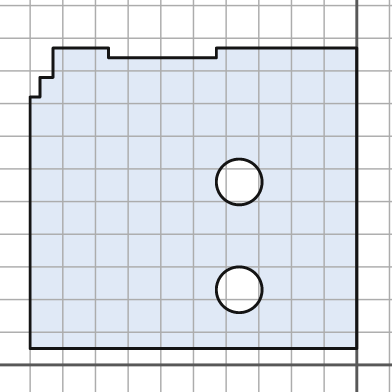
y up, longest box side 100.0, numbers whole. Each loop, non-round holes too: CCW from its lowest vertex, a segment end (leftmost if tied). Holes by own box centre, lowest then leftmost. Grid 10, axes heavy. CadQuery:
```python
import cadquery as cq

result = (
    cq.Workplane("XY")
    .moveTo(-100.0, 5.0)
    .lineTo(0.0, 5.0)
    .lineTo(0.0, 97.0)
    .lineTo(-43.0, 97.0)
    .lineTo(-43.0, 94.0)
    .lineTo(-76.0, 94.0)
    .lineTo(-76.0, 97.0)
    .lineTo(-93.0, 97.0)
    .lineTo(-93.0, 88.0)
    .lineTo(-97.0, 88.0)
    .lineTo(-97.0, 82.0)
    .lineTo(-100.0, 82.0)
    .close()
    .moveTo(-36.0, 23.0)
    .circle(7.0)
    .moveTo(-36.0, 56.0)
    .circle(7.0)
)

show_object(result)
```